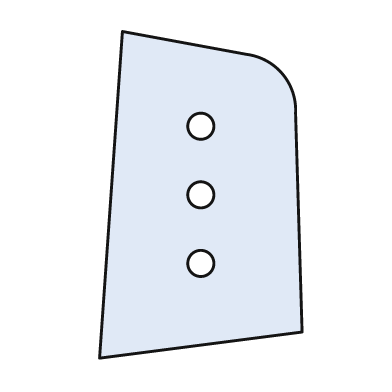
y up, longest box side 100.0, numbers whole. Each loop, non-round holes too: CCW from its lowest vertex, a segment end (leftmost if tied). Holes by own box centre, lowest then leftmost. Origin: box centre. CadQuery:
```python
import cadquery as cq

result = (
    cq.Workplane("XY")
    .moveTo(-31.0, -50.0)
    .lineTo(31.0, -42.0)
    .lineTo(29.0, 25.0)
    .threePointArc((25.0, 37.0), (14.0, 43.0))
    .lineTo(-24.0, 50.0)
    .close()
    .moveTo(0.0, -21.0)
    .circle(4.0)
    .moveTo(0.0, 0.0)
    .circle(4.0)
    .moveTo(0.0, 21.0)
    .circle(4.0)
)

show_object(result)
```